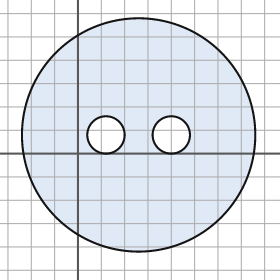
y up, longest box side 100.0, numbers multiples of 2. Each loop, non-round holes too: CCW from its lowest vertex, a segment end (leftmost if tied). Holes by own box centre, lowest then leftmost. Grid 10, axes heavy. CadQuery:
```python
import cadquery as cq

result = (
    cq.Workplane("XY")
    .moveTo(26.0, 8.0)
    .circle(50.0)
    .moveTo(12.0, 8.0)
    .circle(8.0)
    .moveTo(40.0, 8.0)
    .circle(8.0)
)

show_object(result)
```